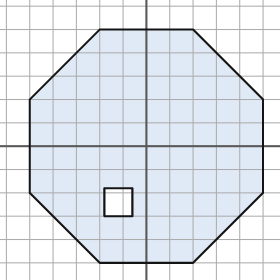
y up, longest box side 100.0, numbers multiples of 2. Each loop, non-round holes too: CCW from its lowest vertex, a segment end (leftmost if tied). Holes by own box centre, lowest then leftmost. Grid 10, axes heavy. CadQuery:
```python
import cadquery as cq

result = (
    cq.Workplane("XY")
    .moveTo(-20.0, -50.0)
    .lineTo(20.0, -50.0)
    .lineTo(50.0, -20.0)
    .lineTo(50.0, 20.0)
    .lineTo(20.0, 50.0)
    .lineTo(-20.0, 50.0)
    .lineTo(-50.0, 20.0)
    .lineTo(-50.0, -20.0)
    .close()
    .moveTo(-18.0, -30.0)
    .lineTo(-6.0, -30.0)
    .lineTo(-6.0, -18.0)
    .lineTo(-18.0, -18.0)
    .close()
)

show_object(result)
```